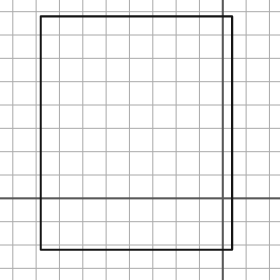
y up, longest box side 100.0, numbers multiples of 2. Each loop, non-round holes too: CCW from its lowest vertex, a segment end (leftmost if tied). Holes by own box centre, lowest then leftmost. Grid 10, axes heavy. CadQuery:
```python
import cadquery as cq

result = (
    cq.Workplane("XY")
    .moveTo(-78.0, -22.0)
    .lineTo(4.0, -22.0)
    .lineTo(4.0, 78.0)
    .lineTo(-78.0, 78.0)
    .close()
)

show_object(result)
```